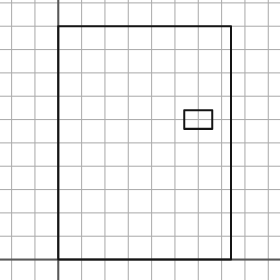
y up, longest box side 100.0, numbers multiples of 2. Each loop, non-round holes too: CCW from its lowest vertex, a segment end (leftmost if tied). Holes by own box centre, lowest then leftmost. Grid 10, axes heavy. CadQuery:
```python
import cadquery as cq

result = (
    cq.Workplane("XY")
    .moveTo(0.0, 0.0)
    .lineTo(74.0, 0.0)
    .lineTo(74.0, 100.0)
    .lineTo(0.0, 100.0)
    .close()
    .moveTo(54.0, 56.0)
    .lineTo(66.0, 56.0)
    .lineTo(66.0, 64.0)
    .lineTo(54.0, 64.0)
    .close()
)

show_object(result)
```